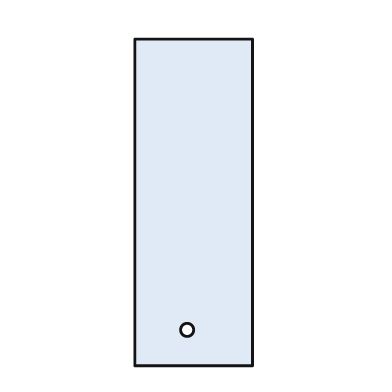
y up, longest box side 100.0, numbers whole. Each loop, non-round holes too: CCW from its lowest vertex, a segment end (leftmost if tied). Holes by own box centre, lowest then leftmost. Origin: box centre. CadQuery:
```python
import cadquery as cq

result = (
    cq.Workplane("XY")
    .moveTo(-18.0, -50.0)
    .lineTo(18.0, -50.0)
    .lineTo(18.0, 50.0)
    .lineTo(-18.0, 50.0)
    .close()
    .moveTo(-2.0, -39.0)
    .circle(2.0)
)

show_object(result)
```